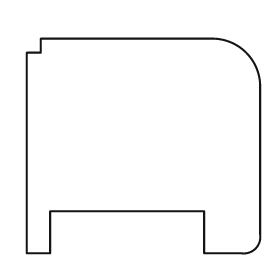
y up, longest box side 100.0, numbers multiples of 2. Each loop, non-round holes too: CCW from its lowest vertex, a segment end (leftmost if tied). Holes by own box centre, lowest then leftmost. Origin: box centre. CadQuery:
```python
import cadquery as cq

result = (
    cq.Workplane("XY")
    .moveTo(-50.0, -46.0)
    .lineTo(-40.0, -46.0)
    .lineTo(-40.0, -28.0)
    .lineTo(26.0, -28.0)
    .lineTo(26.0, -46.0)
    .lineTo(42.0, -46.0)
    .threePointArc((48.0, -44.0), (50.0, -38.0))
    .lineTo(50.0, 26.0)
    .threePointArc((44.0, 40.0), (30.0, 46.0))
    .lineTo(-44.0, 46.0)
    .lineTo(-44.0, 40.0)
    .lineTo(-50.0, 40.0)
    .close()
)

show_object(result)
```